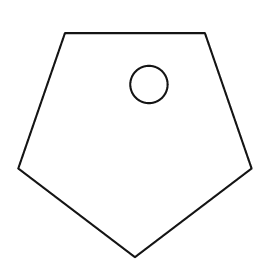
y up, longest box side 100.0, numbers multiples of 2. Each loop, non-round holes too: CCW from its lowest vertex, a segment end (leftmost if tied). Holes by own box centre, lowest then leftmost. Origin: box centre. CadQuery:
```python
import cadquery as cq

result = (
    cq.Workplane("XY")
    .moveTo(0.0, -48.0)
    .lineTo(50.0, -10.0)
    .lineTo(30.0, 48.0)
    .lineTo(-30.0, 48.0)
    .lineTo(-50.0, -10.0)
    .close()
    .moveTo(6.0, 26.0)
    .circle(8.0)
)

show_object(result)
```